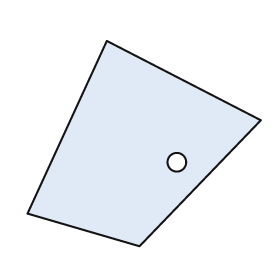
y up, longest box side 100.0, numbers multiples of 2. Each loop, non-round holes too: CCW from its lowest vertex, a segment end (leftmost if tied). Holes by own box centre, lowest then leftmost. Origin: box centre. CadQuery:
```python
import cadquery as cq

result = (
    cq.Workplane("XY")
    .moveTo(-2.0, -44.0)
    .lineTo(50.0, 10.0)
    .lineTo(-16.0, 44.0)
    .lineTo(-50.0, -30.0)
    .close()
    .moveTo(14.0, -8.0)
    .circle(4.0)
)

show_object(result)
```